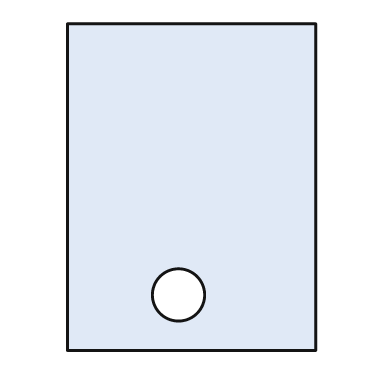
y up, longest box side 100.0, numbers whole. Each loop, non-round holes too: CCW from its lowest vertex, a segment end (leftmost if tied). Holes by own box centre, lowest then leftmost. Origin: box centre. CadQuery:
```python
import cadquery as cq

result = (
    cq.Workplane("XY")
    .moveTo(-38.0, -50.0)
    .lineTo(38.0, -50.0)
    .lineTo(38.0, 50.0)
    .lineTo(-38.0, 50.0)
    .close()
    .moveTo(-4.0, -33.0)
    .circle(8.0)
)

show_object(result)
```